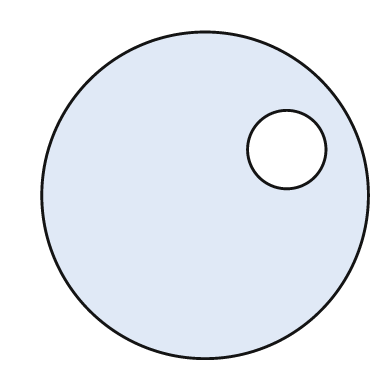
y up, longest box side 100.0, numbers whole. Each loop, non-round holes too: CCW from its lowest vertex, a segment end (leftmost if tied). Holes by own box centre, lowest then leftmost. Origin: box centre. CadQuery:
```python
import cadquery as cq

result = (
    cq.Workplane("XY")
    .moveTo(0.0, 0.0)
    .circle(50.0)
    .moveTo(25.0, 14.0)
    .circle(12.0)
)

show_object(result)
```